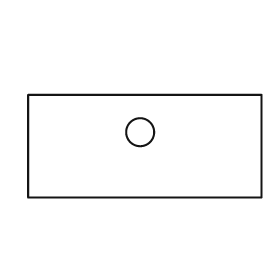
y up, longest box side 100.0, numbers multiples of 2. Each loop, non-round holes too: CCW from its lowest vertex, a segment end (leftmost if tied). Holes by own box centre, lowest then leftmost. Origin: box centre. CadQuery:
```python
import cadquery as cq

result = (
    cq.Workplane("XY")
    .moveTo(-50.0, -22.0)
    .lineTo(50.0, -22.0)
    .lineTo(50.0, 22.0)
    .lineTo(-50.0, 22.0)
    .close()
    .moveTo(-2.0, 6.0)
    .circle(6.0)
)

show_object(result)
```